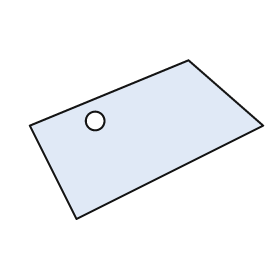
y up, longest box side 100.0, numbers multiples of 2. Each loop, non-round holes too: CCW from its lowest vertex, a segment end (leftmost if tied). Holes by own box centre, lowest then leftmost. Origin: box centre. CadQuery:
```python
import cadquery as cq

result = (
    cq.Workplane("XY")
    .moveTo(-30.0, -34.0)
    .lineTo(50.0, 6.0)
    .lineTo(18.0, 34.0)
    .lineTo(-50.0, 6.0)
    .close()
    .moveTo(-22.0, 8.0)
    .circle(4.0)
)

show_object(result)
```